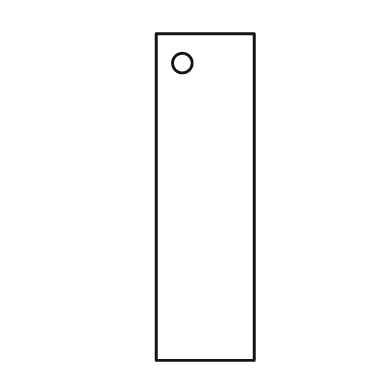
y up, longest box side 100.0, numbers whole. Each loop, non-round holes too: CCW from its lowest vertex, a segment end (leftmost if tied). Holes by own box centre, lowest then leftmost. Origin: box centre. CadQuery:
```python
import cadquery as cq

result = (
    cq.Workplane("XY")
    .moveTo(-15.0, -50.0)
    .lineTo(15.0, -50.0)
    .lineTo(15.0, 50.0)
    .lineTo(-15.0, 50.0)
    .close()
    .moveTo(-7.0, 41.0)
    .circle(3.0)
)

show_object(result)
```